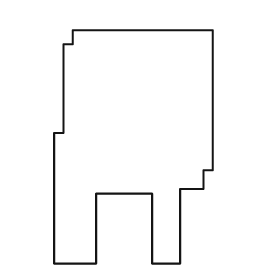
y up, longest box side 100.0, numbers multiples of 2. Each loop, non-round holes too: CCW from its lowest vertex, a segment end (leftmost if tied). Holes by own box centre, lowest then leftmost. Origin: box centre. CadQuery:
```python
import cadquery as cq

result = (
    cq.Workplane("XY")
    .moveTo(-34.0, -50.0)
    .lineTo(-16.0, -50.0)
    .lineTo(-16.0, -20.0)
    .lineTo(8.0, -20.0)
    .lineTo(8.0, -50.0)
    .lineTo(20.0, -50.0)
    .lineTo(20.0, -18.0)
    .lineTo(30.0, -18.0)
    .lineTo(30.0, -10.0)
    .lineTo(34.0, -10.0)
    .lineTo(34.0, 50.0)
    .lineTo(-26.0, 50.0)
    .lineTo(-26.0, 44.0)
    .lineTo(-30.0, 44.0)
    .lineTo(-30.0, 6.0)
    .lineTo(-34.0, 6.0)
    .close()
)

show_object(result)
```